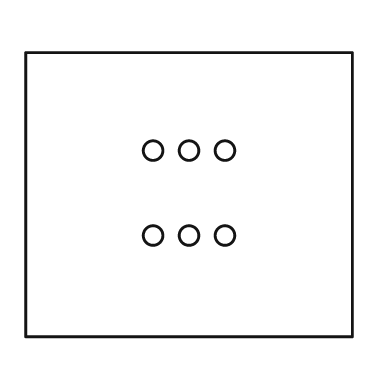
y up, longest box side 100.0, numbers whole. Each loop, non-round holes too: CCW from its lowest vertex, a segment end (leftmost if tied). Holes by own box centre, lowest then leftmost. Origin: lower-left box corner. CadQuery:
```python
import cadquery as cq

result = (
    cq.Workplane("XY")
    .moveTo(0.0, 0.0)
    .lineTo(100.0, 0.0)
    .lineTo(100.0, 87.0)
    .lineTo(0.0, 87.0)
    .close()
    .moveTo(39.0, 31.0)
    .circle(3.0)
    .moveTo(50.0, 31.0)
    .circle(3.0)
    .moveTo(61.0, 31.0)
    .circle(3.0)
    .moveTo(39.0, 57.0)
    .circle(3.0)
    .moveTo(50.0, 57.0)
    .circle(3.0)
    .moveTo(61.0, 57.0)
    .circle(3.0)
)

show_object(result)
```